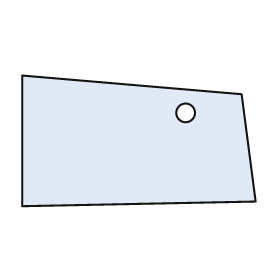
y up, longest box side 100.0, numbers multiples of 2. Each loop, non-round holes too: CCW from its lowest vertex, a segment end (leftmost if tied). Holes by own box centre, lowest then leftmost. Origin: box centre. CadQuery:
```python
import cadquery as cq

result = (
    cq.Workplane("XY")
    .moveTo(-50.0, -28.0)
    .lineTo(50.0, -26.0)
    .lineTo(44.0, 20.0)
    .lineTo(-50.0, 28.0)
    .close()
    .moveTo(20.0, 12.0)
    .circle(4.0)
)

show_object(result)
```